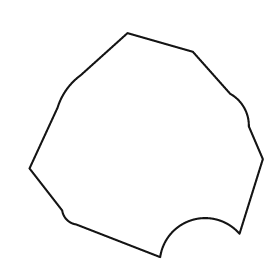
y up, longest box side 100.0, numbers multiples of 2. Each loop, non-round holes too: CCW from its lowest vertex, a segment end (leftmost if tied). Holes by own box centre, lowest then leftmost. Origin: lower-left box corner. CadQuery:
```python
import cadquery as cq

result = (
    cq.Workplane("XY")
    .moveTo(56.0, 0.0)
    .threePointArc((70.0, 16.0), (90.0, 10.0))
    .lineTo(100.0, 42.0)
    .lineTo(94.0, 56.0)
    .threePointArc((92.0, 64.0), (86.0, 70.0))
    .lineTo(70.0, 88.0)
    .lineTo(42.0, 96.0)
    .lineTo(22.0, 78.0)
    .threePointArc((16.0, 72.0), (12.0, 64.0))
    .lineTo(0.0, 38.0)
    .lineTo(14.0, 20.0)
    .threePointArc((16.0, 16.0), (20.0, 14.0))
    .close()
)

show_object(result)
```